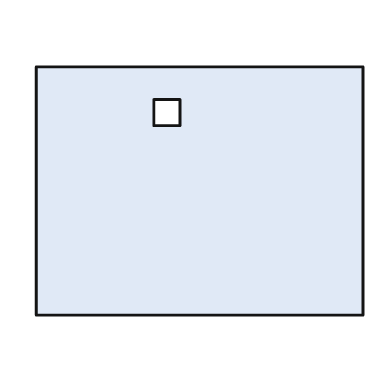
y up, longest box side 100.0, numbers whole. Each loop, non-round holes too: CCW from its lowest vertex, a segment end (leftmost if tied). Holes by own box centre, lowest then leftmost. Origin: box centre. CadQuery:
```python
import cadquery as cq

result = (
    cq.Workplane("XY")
    .moveTo(-50.0, -38.0)
    .lineTo(50.0, -38.0)
    .lineTo(50.0, 38.0)
    .lineTo(-50.0, 38.0)
    .close()
    .moveTo(-14.0, 20.0)
    .lineTo(-6.0, 20.0)
    .lineTo(-6.0, 28.0)
    .lineTo(-14.0, 28.0)
    .close()
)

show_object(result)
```